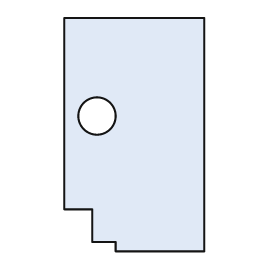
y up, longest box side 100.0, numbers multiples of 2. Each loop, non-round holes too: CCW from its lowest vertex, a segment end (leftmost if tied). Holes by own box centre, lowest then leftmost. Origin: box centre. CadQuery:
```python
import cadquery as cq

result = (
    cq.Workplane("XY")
    .moveTo(-8.0, -50.0)
    .lineTo(30.0, -50.0)
    .lineTo(30.0, 50.0)
    .lineTo(-30.0, 50.0)
    .lineTo(-30.0, -32.0)
    .lineTo(-18.0, -32.0)
    .lineTo(-18.0, -46.0)
    .lineTo(-8.0, -46.0)
    .close()
    .moveTo(-16.0, 8.0)
    .circle(8.0)
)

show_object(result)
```